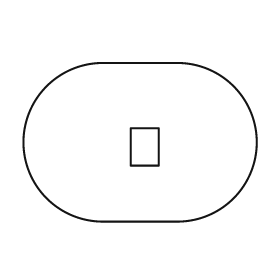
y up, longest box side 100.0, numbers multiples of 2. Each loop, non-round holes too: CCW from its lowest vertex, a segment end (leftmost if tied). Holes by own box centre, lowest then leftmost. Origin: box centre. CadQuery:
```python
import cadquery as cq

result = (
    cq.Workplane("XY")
    .moveTo(-16.0, -34.0)
    .lineTo(16.0, -34.0)
    .threePointArc((50.0, 0.0), (16.0, 34.0))
    .lineTo(-16.0, 34.0)
    .threePointArc((-50.0, 0.0), (-16.0, -34.0))
    .close()
    .moveTo(-4.0, -10.0)
    .lineTo(8.0, -10.0)
    .lineTo(8.0, 6.0)
    .lineTo(-4.0, 6.0)
    .close()
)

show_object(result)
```